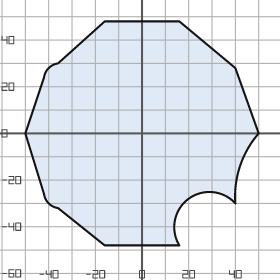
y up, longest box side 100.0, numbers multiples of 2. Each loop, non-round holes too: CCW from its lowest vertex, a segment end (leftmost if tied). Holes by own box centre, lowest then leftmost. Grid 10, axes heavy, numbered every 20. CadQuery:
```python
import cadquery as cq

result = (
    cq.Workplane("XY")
    .moveTo(-16.0, -48.0)
    .lineTo(16.0, -48.0)
    .threePointArc((20.0, -28.0), (40.0, -30.0))
    .threePointArc((42.0, -14.0), (50.0, 0.0))
    .lineTo(40.0, 28.0)
    .lineTo(16.0, 48.0)
    .lineTo(-16.0, 48.0)
    .lineTo(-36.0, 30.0)
    .threePointArc((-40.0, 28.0), (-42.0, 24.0))
    .lineTo(-50.0, 0.0)
    .lineTo(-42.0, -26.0)
    .threePointArc((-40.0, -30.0), (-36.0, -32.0))
    .close()
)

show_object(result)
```